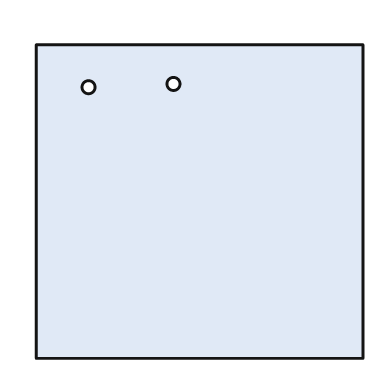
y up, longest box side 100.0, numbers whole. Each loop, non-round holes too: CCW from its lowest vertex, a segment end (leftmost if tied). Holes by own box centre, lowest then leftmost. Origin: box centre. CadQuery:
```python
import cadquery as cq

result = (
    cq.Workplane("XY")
    .moveTo(-50.0, -48.0)
    .lineTo(50.0, -48.0)
    .lineTo(50.0, 48.0)
    .lineTo(-50.0, 48.0)
    .close()
    .moveTo(-34.0, 35.0)
    .circle(2.0)
    .moveTo(-8.0, 36.0)
    .circle(2.0)
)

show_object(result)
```